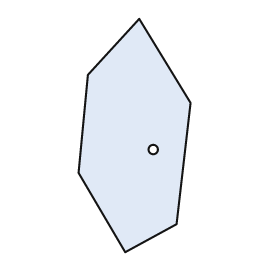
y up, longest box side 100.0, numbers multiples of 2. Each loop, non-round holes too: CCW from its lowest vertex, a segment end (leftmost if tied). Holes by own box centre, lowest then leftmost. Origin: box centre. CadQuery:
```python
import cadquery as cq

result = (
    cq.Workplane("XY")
    .moveTo(-4.0, -50.0)
    .lineTo(18.0, -38.0)
    .lineTo(24.0, 14.0)
    .lineTo(2.0, 50.0)
    .lineTo(-20.0, 26.0)
    .lineTo(-24.0, -16.0)
    .close()
    .moveTo(8.0, -6.0)
    .circle(2.0)
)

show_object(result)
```